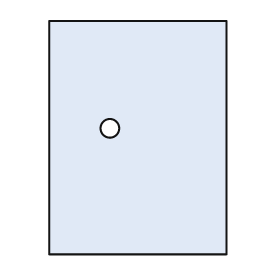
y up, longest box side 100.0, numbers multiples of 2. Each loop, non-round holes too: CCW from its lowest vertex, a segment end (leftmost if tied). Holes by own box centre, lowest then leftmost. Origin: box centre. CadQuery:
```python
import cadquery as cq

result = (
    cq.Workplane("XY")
    .moveTo(-38.0, -50.0)
    .lineTo(38.0, -50.0)
    .lineTo(38.0, 50.0)
    .lineTo(-38.0, 50.0)
    .close()
    .moveTo(-12.0, 4.0)
    .circle(4.0)
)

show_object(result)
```